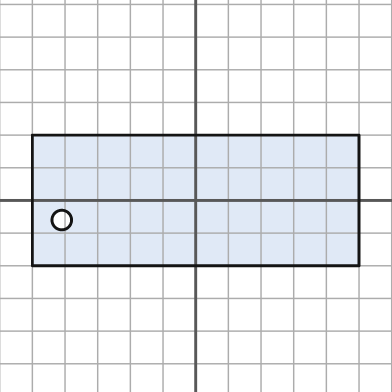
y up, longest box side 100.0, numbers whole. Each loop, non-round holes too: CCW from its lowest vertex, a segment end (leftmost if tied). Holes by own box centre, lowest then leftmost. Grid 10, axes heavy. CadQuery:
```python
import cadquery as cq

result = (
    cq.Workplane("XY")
    .moveTo(-50.0, -20.0)
    .lineTo(50.0, -20.0)
    .lineTo(50.0, 20.0)
    .lineTo(-50.0, 20.0)
    .close()
    .moveTo(-41.0, -6.0)
    .circle(3.0)
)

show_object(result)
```